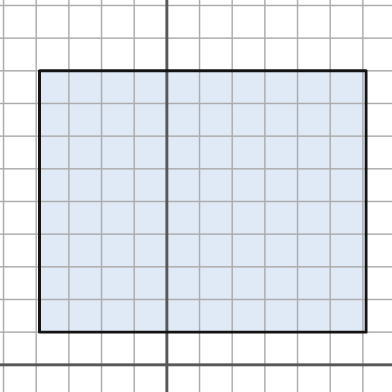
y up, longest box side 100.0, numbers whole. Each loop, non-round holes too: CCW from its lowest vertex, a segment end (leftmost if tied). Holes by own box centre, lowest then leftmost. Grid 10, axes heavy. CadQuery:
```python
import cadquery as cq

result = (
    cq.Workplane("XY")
    .moveTo(-39.0, 10.0)
    .lineTo(61.0, 10.0)
    .lineTo(61.0, 90.0)
    .lineTo(-39.0, 90.0)
    .close()
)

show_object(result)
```